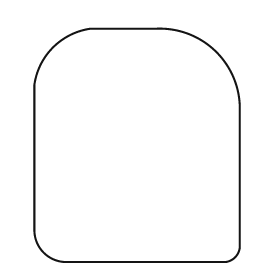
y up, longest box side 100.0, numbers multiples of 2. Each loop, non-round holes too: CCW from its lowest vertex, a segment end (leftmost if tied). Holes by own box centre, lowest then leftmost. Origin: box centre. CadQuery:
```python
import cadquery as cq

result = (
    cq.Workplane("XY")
    .moveTo(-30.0, -50.0)
    .lineTo(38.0, -50.0)
    .threePointArc((42.0, -48.0), (44.0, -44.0))
    .lineTo(44.0, 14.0)
    .threePointArc((34.0, 40.0), (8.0, 50.0))
    .lineTo(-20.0, 50.0)
    .threePointArc((-36.0, 42.0), (-44.0, 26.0))
    .lineTo(-44.0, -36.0)
    .threePointArc((-40.0, -46.0), (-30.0, -50.0))
    .close()
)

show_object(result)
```